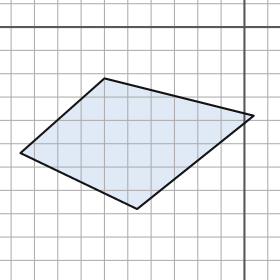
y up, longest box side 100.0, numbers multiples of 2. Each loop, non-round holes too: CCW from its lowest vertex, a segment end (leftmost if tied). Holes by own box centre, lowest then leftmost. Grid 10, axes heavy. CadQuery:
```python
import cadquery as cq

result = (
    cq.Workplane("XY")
    .moveTo(-46.0, -78.0)
    .lineTo(4.0, -38.0)
    .lineTo(-60.0, -22.0)
    .lineTo(-96.0, -54.0)
    .close()
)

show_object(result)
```